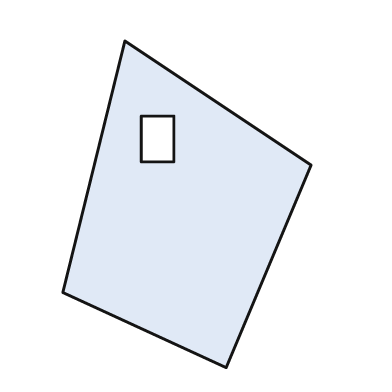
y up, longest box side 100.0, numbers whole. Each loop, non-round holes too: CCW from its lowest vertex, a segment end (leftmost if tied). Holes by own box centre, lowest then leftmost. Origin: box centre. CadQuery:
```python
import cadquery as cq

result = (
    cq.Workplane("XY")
    .moveTo(12.0, -50.0)
    .lineTo(38.0, 12.0)
    .lineTo(-19.0, 50.0)
    .lineTo(-38.0, -27.0)
    .close()
    .moveTo(-14.0, 13.0)
    .lineTo(-4.0, 13.0)
    .lineTo(-4.0, 27.0)
    .lineTo(-14.0, 27.0)
    .close()
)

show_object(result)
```